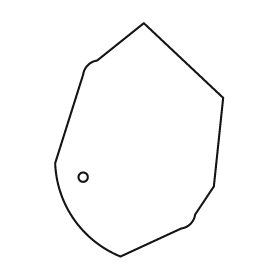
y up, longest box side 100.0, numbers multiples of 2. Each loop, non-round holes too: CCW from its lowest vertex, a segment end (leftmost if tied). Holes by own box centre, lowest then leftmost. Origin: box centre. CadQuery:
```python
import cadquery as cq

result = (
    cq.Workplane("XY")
    .moveTo(-8.0, -50.0)
    .lineTo(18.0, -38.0)
    .threePointArc((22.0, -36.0), (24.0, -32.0))
    .lineTo(32.0, -20.0)
    .lineTo(36.0, 18.0)
    .lineTo(2.0, 50.0)
    .lineTo(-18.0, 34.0)
    .threePointArc((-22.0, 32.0), (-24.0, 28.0))
    .lineTo(-36.0, -10.0)
    .threePointArc((-28.0, -34.0), (-8.0, -50.0))
    .close()
    .moveTo(-24.0, -16.0)
    .circle(2.0)
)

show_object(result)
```